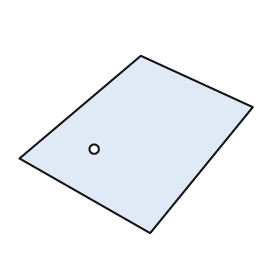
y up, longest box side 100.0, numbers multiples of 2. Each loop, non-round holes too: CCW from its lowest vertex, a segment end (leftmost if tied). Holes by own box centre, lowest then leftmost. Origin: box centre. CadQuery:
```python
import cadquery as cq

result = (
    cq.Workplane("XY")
    .moveTo(6.0, -38.0)
    .lineTo(50.0, 16.0)
    .lineTo(2.0, 38.0)
    .lineTo(-50.0, -6.0)
    .close()
    .moveTo(-18.0, -2.0)
    .circle(2.0)
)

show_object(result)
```